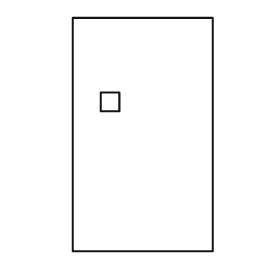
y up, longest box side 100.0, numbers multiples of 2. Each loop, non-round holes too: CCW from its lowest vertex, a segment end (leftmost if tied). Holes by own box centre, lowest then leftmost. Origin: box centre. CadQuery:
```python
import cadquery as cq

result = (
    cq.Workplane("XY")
    .moveTo(-30.0, -50.0)
    .lineTo(30.0, -50.0)
    .lineTo(30.0, 50.0)
    .lineTo(-30.0, 50.0)
    .close()
    .moveTo(-18.0, 10.0)
    .lineTo(-10.0, 10.0)
    .lineTo(-10.0, 18.0)
    .lineTo(-18.0, 18.0)
    .close()
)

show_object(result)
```